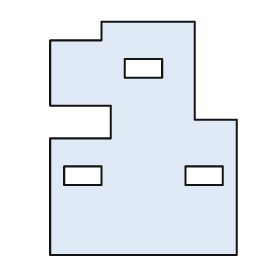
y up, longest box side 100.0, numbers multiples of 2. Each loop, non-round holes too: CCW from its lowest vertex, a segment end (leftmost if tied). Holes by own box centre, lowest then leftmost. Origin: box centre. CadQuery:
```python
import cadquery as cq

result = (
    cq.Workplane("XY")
    .moveTo(-40.0, -50.0)
    .lineTo(40.0, -50.0)
    .lineTo(40.0, 8.0)
    .lineTo(22.0, 8.0)
    .lineTo(22.0, 50.0)
    .lineTo(-18.0, 50.0)
    .lineTo(-18.0, 42.0)
    .lineTo(-40.0, 42.0)
    .lineTo(-40.0, 14.0)
    .lineTo(-14.0, 14.0)
    .lineTo(-14.0, 0.0)
    .lineTo(-40.0, 0.0)
    .close()
    .moveTo(-34.0, -20.0)
    .lineTo(-18.0, -20.0)
    .lineTo(-18.0, -12.0)
    .lineTo(-34.0, -12.0)
    .close()
    .moveTo(18.0, -20.0)
    .lineTo(34.0, -20.0)
    .lineTo(34.0, -12.0)
    .lineTo(18.0, -12.0)
    .close()
    .moveTo(-8.0, 26.0)
    .lineTo(8.0, 26.0)
    .lineTo(8.0, 34.0)
    .lineTo(-8.0, 34.0)
    .close()
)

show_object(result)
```